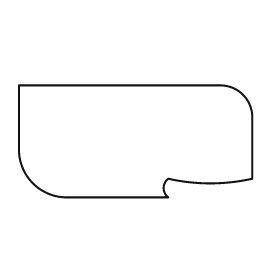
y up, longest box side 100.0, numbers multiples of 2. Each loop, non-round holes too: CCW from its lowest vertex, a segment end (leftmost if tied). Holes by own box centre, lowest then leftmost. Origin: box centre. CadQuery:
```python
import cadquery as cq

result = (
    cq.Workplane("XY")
    .moveTo(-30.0, -24.0)
    .lineTo(14.0, -24.0)
    .threePointArc((12.0, -20.0), (14.0, -16.0))
    .threePointArc((32.0, -18.0), (50.0, -16.0))
    .lineTo(50.0, 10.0)
    .threePointArc((46.0, 20.0), (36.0, 24.0))
    .lineTo(-50.0, 24.0)
    .lineTo(-50.0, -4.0)
    .threePointArc((-44.0, -18.0), (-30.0, -24.0))
    .close()
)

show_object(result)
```